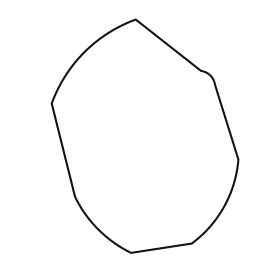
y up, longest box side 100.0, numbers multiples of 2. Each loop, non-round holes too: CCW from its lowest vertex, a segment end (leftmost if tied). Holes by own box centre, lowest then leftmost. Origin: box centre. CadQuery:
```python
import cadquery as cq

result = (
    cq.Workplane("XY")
    .moveTo(-6.0, -50.0)
    .lineTo(20.0, -46.0)
    .threePointArc((34.0, -30.0), (40.0, -10.0))
    .lineTo(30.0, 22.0)
    .threePointArc((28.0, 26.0), (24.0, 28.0))
    .lineTo(-4.0, 50.0)
    .threePointArc((-26.0, 36.0), (-40.0, 14.0))
    .lineTo(-30.0, -26.0)
    .threePointArc((-20.0, -40.0), (-6.0, -50.0))
    .close()
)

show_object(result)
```